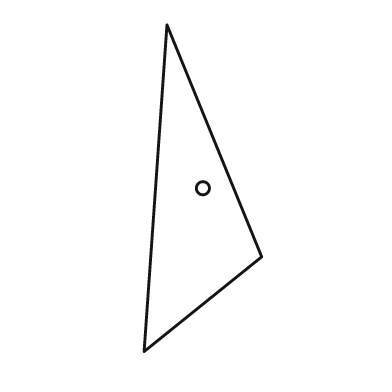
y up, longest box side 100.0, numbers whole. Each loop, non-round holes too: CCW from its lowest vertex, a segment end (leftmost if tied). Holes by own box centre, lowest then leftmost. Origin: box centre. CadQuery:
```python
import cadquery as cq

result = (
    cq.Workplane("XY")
    .moveTo(-18.0, -50.0)
    .lineTo(18.0, -21.0)
    .lineTo(-11.0, 50.0)
    .close()
    .moveTo(0.0, 0.0)
    .circle(2.0)
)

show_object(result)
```